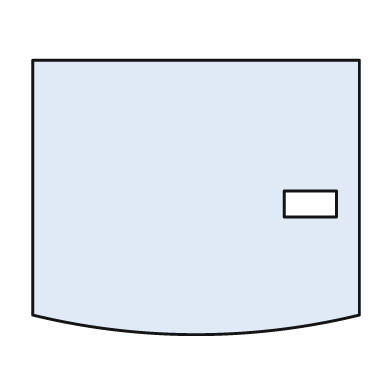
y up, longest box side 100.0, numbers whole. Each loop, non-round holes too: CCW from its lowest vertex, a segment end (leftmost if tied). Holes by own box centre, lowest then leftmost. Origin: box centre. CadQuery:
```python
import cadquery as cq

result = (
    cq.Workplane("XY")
    .moveTo(-50.0, -36.0)
    .threePointArc((0.0, -42.0), (50.0, -36.0))
    .lineTo(50.0, 42.0)
    .lineTo(-50.0, 42.0)
    .close()
    .moveTo(27.0, -6.0)
    .lineTo(43.0, -6.0)
    .lineTo(43.0, 2.0)
    .lineTo(27.0, 2.0)
    .close()
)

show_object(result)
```